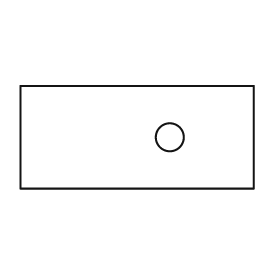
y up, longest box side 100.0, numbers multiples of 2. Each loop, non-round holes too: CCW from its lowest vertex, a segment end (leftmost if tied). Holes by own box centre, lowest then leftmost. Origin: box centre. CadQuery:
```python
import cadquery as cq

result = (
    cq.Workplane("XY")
    .moveTo(-50.0, -22.0)
    .lineTo(50.0, -22.0)
    .lineTo(50.0, 22.0)
    .lineTo(-50.0, 22.0)
    .close()
    .moveTo(14.0, 0.0)
    .circle(6.0)
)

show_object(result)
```